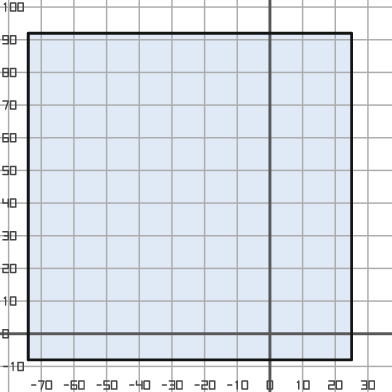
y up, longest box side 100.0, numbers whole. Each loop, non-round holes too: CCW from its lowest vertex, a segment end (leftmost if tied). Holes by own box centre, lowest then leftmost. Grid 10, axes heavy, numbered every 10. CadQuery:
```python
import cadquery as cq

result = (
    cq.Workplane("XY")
    .moveTo(-74.0, -8.0)
    .lineTo(25.0, -8.0)
    .lineTo(25.0, 92.0)
    .lineTo(-74.0, 92.0)
    .close()
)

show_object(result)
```